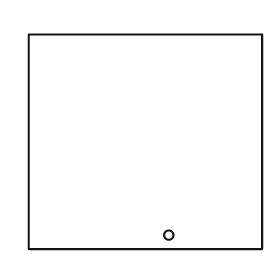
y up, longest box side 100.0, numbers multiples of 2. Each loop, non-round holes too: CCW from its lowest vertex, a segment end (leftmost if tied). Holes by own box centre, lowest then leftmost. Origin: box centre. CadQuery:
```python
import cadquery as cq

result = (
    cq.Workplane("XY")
    .moveTo(-50.0, -46.0)
    .lineTo(50.0, -46.0)
    .lineTo(50.0, 46.0)
    .lineTo(-50.0, 46.0)
    .close()
    .moveTo(10.0, -40.0)
    .circle(2.0)
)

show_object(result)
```